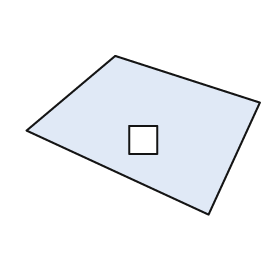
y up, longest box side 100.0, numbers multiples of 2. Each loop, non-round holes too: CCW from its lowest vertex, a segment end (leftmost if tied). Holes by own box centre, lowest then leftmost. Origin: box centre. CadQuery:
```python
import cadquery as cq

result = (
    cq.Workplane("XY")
    .moveTo(28.0, -34.0)
    .lineTo(50.0, 14.0)
    .lineTo(-12.0, 34.0)
    .lineTo(-50.0, 2.0)
    .close()
    .moveTo(-6.0, -8.0)
    .lineTo(6.0, -8.0)
    .lineTo(6.0, 4.0)
    .lineTo(-6.0, 4.0)
    .close()
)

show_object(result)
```